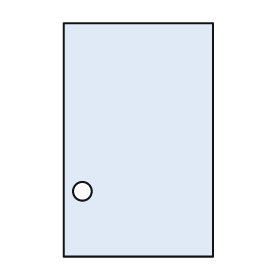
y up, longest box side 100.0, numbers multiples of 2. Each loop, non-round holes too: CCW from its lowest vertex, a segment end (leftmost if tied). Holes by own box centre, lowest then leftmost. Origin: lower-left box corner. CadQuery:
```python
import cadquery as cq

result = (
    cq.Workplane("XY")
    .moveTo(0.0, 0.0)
    .lineTo(64.0, 0.0)
    .lineTo(64.0, 100.0)
    .lineTo(0.0, 100.0)
    .close()
    .moveTo(8.0, 28.0)
    .circle(4.0)
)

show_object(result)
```